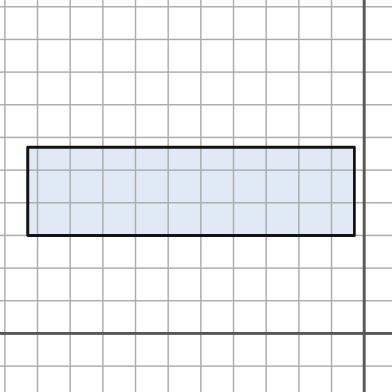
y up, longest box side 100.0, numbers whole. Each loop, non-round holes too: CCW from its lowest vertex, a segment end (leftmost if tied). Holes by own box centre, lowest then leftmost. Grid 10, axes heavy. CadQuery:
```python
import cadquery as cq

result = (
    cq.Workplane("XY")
    .moveTo(-103.0, 30.0)
    .lineTo(-3.0, 30.0)
    .lineTo(-3.0, 57.0)
    .lineTo(-103.0, 57.0)
    .close()
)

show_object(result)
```